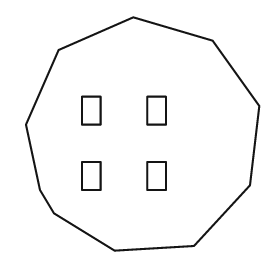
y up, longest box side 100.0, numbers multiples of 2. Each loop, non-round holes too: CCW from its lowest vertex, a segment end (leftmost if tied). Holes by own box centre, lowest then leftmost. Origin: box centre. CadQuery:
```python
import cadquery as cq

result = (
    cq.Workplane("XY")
    .moveTo(-12.0, -50.0)
    .lineTo(22.0, -48.0)
    .lineTo(46.0, -22.0)
    .lineTo(50.0, 12.0)
    .lineTo(30.0, 40.0)
    .lineTo(-4.0, 50.0)
    .lineTo(-36.0, 36.0)
    .lineTo(-50.0, 4.0)
    .lineTo(-44.0, -24.0)
    .lineTo(-38.0, -34.0)
    .close()
    .moveTo(-26.0, -24.0)
    .lineTo(-18.0, -24.0)
    .lineTo(-18.0, -12.0)
    .lineTo(-26.0, -12.0)
    .close()
    .moveTo(2.0, -24.0)
    .lineTo(10.0, -24.0)
    .lineTo(10.0, -12.0)
    .lineTo(2.0, -12.0)
    .close()
    .moveTo(-26.0, 4.0)
    .lineTo(-18.0, 4.0)
    .lineTo(-18.0, 16.0)
    .lineTo(-26.0, 16.0)
    .close()
    .moveTo(2.0, 4.0)
    .lineTo(10.0, 4.0)
    .lineTo(10.0, 16.0)
    .lineTo(2.0, 16.0)
    .close()
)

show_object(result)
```